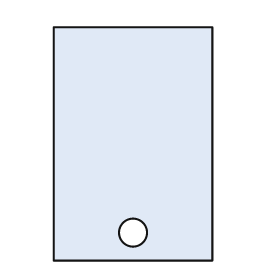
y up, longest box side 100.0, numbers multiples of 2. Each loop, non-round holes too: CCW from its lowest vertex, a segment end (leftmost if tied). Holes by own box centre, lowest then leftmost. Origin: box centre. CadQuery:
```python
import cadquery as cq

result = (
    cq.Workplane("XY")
    .moveTo(-34.0, -50.0)
    .lineTo(34.0, -50.0)
    .lineTo(34.0, 50.0)
    .lineTo(-34.0, 50.0)
    .close()
    .moveTo(0.0, -38.0)
    .circle(6.0)
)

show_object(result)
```